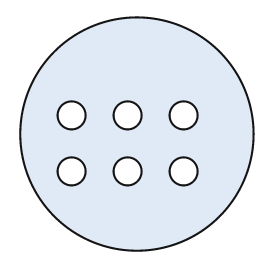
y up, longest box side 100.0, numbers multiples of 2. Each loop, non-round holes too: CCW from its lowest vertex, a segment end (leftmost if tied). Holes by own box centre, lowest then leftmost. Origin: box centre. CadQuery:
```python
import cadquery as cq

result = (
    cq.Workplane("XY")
    .moveTo(0.0, 0.0)
    .circle(50.0)
    .moveTo(-28.0, -16.0)
    .circle(6.0)
    .moveTo(-4.0, -16.0)
    .circle(6.0)
    .moveTo(20.0, -16.0)
    .circle(6.0)
    .moveTo(-28.0, 8.0)
    .circle(6.0)
    .moveTo(-4.0, 8.0)
    .circle(6.0)
    .moveTo(20.0, 8.0)
    .circle(6.0)
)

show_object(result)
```